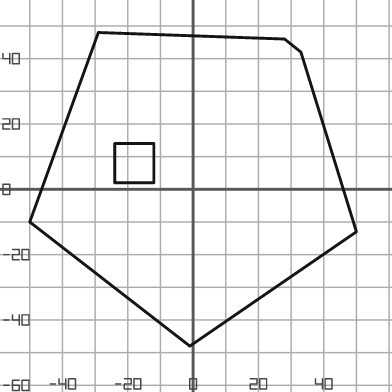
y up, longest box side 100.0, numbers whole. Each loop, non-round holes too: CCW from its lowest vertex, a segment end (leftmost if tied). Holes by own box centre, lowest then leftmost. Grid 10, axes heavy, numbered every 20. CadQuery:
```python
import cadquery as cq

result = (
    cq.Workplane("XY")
    .moveTo(-1.0, -48.0)
    .lineTo(50.0, -13.0)
    .lineTo(33.0, 42.0)
    .lineTo(28.0, 46.0)
    .lineTo(-29.0, 48.0)
    .lineTo(-50.0, -10.0)
    .close()
    .moveTo(-24.0, 2.0)
    .lineTo(-12.0, 2.0)
    .lineTo(-12.0, 14.0)
    .lineTo(-24.0, 14.0)
    .close()
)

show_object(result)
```